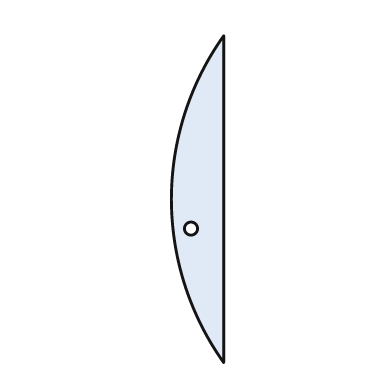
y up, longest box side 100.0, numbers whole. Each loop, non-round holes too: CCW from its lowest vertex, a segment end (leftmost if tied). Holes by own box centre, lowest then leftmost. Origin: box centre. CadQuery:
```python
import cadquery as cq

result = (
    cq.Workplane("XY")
    .moveTo(8.0, -50.0)
    .lineTo(8.0, 50.0)
    .threePointArc((-8.0, 0.0), (8.0, -50.0))
    .close()
    .moveTo(-2.0, -9.0)
    .circle(2.0)
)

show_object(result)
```